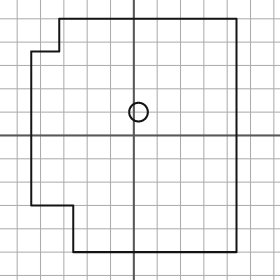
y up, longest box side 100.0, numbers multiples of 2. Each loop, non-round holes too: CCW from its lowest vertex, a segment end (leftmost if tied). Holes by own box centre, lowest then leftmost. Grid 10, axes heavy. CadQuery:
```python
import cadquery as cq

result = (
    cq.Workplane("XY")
    .moveTo(-26.0, -50.0)
    .lineTo(44.0, -50.0)
    .lineTo(44.0, 50.0)
    .lineTo(-32.0, 50.0)
    .lineTo(-32.0, 36.0)
    .lineTo(-44.0, 36.0)
    .lineTo(-44.0, -30.0)
    .lineTo(-26.0, -30.0)
    .close()
    .moveTo(2.0, 10.0)
    .circle(4.0)
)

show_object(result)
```